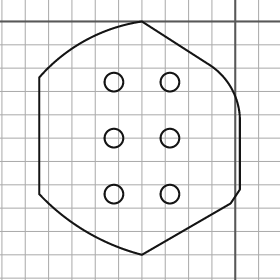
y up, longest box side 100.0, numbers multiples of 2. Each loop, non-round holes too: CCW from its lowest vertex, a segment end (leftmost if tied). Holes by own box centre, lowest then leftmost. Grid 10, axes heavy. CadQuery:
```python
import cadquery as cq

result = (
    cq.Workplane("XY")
    .moveTo(-40.0, -100.0)
    .lineTo(-2.0, -78.0)
    .lineTo(2.0, -72.0)
    .lineTo(2.0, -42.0)
    .threePointArc((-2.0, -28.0), (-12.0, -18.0))
    .lineTo(-40.0, 0.0)
    .threePointArc((-64.0, -8.0), (-84.0, -24.0))
    .lineTo(-84.0, -74.0)
    .threePointArc((-64.0, -90.0), (-40.0, -100.0))
    .close()
    .moveTo(-52.0, -74.0)
    .circle(4.0)
    .moveTo(-28.0, -74.0)
    .circle(4.0)
    .moveTo(-52.0, -50.0)
    .circle(4.0)
    .moveTo(-28.0, -50.0)
    .circle(4.0)
    .moveTo(-52.0, -26.0)
    .circle(4.0)
    .moveTo(-28.0, -26.0)
    .circle(4.0)
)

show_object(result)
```